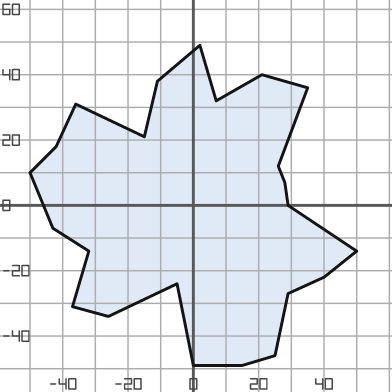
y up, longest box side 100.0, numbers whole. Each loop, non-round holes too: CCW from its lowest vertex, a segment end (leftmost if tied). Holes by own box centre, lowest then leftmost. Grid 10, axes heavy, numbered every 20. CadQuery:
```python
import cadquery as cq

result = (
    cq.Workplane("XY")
    .moveTo(0.0, -49.0)
    .lineTo(15.0, -49.0)
    .lineTo(25.0, -46.0)
    .lineTo(29.0, -27.0)
    .lineTo(40.0, -22.0)
    .lineTo(50.0, -14.0)
    .lineTo(29.0, 0.0)
    .lineTo(28.0, 7.0)
    .lineTo(26.0, 12.0)
    .lineTo(35.0, 36.0)
    .lineTo(21.0, 40.0)
    .lineTo(7.0, 32.0)
    .lineTo(2.0, 49.0)
    .lineTo(-11.0, 38.0)
    .lineTo(-15.0, 21.0)
    .lineTo(-36.0, 31.0)
    .lineTo(-42.0, 18.0)
    .lineTo(-50.0, 10.0)
    .lineTo(-43.0, -7.0)
    .lineTo(-32.0, -14.0)
    .lineTo(-37.0, -31.0)
    .lineTo(-26.0, -34.0)
    .lineTo(-5.0, -24.0)
    .close()
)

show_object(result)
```